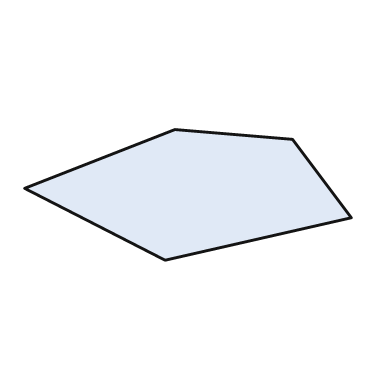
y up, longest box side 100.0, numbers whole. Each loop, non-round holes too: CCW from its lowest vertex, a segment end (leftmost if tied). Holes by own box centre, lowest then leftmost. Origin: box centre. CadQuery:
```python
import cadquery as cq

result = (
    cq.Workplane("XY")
    .moveTo(-7.0, -20.0)
    .lineTo(50.0, -7.0)
    .lineTo(32.0, 17.0)
    .lineTo(-4.0, 20.0)
    .lineTo(-50.0, 2.0)
    .close()
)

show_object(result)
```